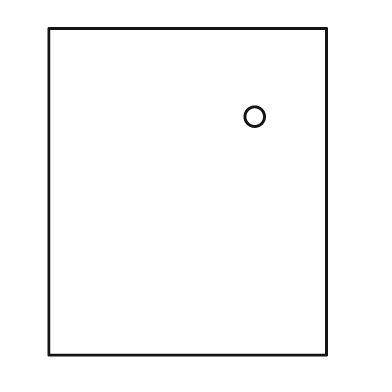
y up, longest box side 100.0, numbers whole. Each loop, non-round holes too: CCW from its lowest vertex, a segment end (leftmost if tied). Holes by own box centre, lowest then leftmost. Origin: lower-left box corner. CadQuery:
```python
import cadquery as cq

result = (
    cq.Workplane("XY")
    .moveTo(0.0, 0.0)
    .lineTo(85.0, 0.0)
    .lineTo(85.0, 100.0)
    .lineTo(0.0, 100.0)
    .close()
    .moveTo(63.0, 73.0)
    .circle(3.0)
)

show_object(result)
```